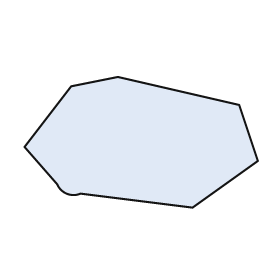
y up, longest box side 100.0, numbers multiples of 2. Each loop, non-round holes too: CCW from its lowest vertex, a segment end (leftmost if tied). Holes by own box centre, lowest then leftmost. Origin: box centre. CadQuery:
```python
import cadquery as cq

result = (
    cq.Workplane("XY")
    .moveTo(22.0, -28.0)
    .lineTo(50.0, -8.0)
    .lineTo(42.0, 16.0)
    .lineTo(-10.0, 28.0)
    .lineTo(-30.0, 24.0)
    .lineTo(-50.0, -2.0)
    .lineTo(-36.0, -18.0)
    .threePointArc((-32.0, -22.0), (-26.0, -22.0))
    .close()
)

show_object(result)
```